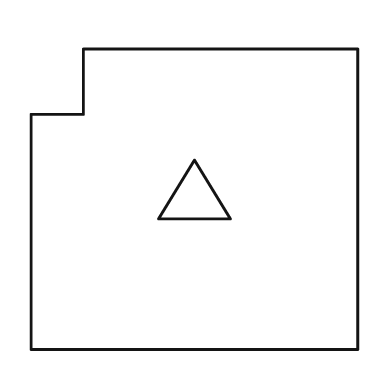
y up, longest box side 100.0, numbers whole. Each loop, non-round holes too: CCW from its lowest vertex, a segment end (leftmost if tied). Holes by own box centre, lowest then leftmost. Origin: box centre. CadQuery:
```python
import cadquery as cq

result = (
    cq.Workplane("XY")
    .moveTo(-50.0, -46.0)
    .lineTo(50.0, -46.0)
    .lineTo(50.0, 46.0)
    .lineTo(-34.0, 46.0)
    .lineTo(-34.0, 26.0)
    .lineTo(-50.0, 26.0)
    .close()
    .moveTo(-11.0, -6.0)
    .lineTo(11.0, -6.0)
    .lineTo(0.0, 12.0)
    .close()
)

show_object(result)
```